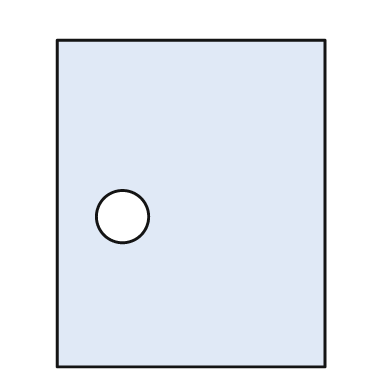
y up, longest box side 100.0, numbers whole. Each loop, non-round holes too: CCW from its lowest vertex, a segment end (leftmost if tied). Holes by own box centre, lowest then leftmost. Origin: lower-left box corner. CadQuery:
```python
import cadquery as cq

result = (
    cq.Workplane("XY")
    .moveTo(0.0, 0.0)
    .lineTo(82.0, 0.0)
    .lineTo(82.0, 100.0)
    .lineTo(0.0, 100.0)
    .close()
    .moveTo(20.0, 46.0)
    .circle(8.0)
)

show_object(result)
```